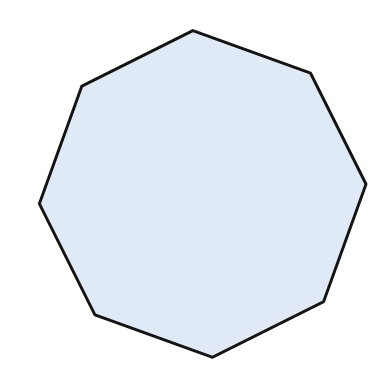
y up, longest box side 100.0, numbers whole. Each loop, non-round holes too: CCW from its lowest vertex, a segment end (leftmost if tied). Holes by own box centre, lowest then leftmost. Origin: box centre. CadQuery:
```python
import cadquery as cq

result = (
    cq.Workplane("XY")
    .moveTo(3.0, -50.0)
    .lineTo(37.0, -33.0)
    .lineTo(50.0, 3.0)
    .lineTo(33.0, 37.0)
    .lineTo(-3.0, 50.0)
    .lineTo(-37.0, 33.0)
    .lineTo(-50.0, -3.0)
    .lineTo(-33.0, -37.0)
    .close()
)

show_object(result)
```